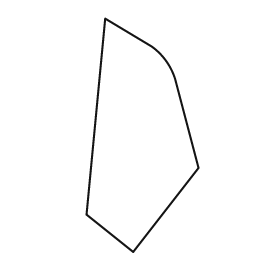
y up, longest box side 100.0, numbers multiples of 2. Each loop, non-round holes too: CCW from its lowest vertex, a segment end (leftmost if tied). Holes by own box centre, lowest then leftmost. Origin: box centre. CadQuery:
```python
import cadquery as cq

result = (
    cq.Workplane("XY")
    .moveTo(-4.0, -50.0)
    .lineTo(24.0, -14.0)
    .lineTo(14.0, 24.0)
    .threePointArc((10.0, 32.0), (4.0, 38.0))
    .lineTo(-16.0, 50.0)
    .lineTo(-24.0, -34.0)
    .close()
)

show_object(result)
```